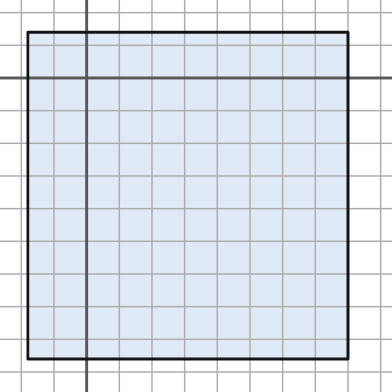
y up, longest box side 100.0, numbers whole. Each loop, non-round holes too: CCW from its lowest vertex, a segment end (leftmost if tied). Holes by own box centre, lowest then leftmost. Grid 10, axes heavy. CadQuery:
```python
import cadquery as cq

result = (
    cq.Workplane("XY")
    .moveTo(-18.0, -86.0)
    .lineTo(80.0, -86.0)
    .lineTo(80.0, 14.0)
    .lineTo(-18.0, 14.0)
    .close()
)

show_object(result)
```